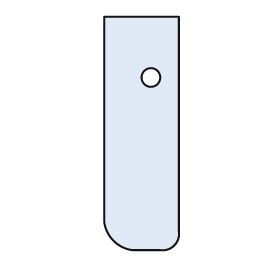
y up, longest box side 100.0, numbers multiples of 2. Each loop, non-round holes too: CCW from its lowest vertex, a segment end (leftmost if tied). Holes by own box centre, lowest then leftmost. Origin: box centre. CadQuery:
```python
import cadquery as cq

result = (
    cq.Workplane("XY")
    .moveTo(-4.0, -50.0)
    .lineTo(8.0, -50.0)
    .threePointArc((14.0, -48.0), (16.0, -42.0))
    .lineTo(16.0, 50.0)
    .lineTo(-16.0, 50.0)
    .lineTo(-16.0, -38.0)
    .threePointArc((-12.0, -46.0), (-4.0, -50.0))
    .close()
    .moveTo(4.0, 24.0)
    .circle(4.0)
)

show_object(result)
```